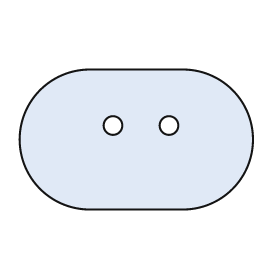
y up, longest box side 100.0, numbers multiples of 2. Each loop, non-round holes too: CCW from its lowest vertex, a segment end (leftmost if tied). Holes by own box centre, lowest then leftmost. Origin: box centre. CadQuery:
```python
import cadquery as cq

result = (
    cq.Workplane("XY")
    .moveTo(-20.0, -30.0)
    .lineTo(20.0, -30.0)
    .threePointArc((50.0, 0.0), (20.0, 30.0))
    .lineTo(-20.0, 30.0)
    .threePointArc((-50.0, 0.0), (-20.0, -30.0))
    .close()
    .moveTo(-10.0, 6.0)
    .circle(4.0)
    .moveTo(14.0, 6.0)
    .circle(4.0)
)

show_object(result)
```